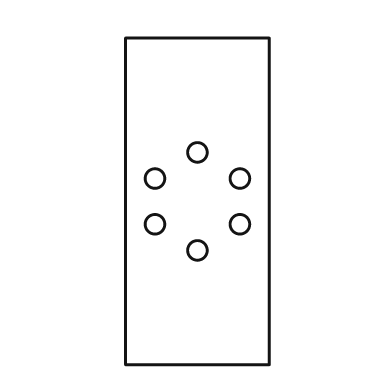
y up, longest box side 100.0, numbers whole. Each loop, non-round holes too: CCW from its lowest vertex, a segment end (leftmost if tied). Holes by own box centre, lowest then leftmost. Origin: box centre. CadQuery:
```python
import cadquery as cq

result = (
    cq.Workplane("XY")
    .moveTo(-22.0, -50.0)
    .lineTo(22.0, -50.0)
    .lineTo(22.0, 50.0)
    .lineTo(-22.0, 50.0)
    .close()
    .moveTo(0.0, -15.0)
    .circle(3.0)
    .moveTo(-13.0, -7.0)
    .circle(3.0)
    .moveTo(13.0, -7.0)
    .circle(3.0)
    .moveTo(-13.0, 7.0)
    .circle(3.0)
    .moveTo(13.0, 7.0)
    .circle(3.0)
    .moveTo(0.0, 15.0)
    .circle(3.0)
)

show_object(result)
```